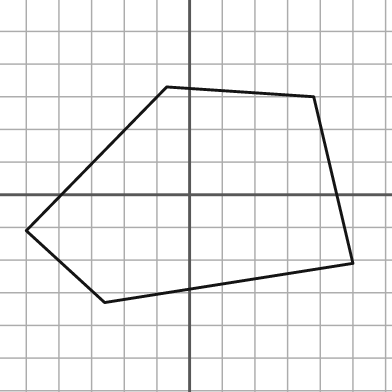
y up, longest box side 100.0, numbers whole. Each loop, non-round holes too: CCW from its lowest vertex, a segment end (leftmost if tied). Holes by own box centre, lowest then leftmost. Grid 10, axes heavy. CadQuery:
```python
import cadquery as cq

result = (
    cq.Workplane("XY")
    .moveTo(-26.0, -33.0)
    .lineTo(50.0, -21.0)
    .lineTo(38.0, 30.0)
    .lineTo(-7.0, 33.0)
    .lineTo(-50.0, -11.0)
    .close()
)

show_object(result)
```